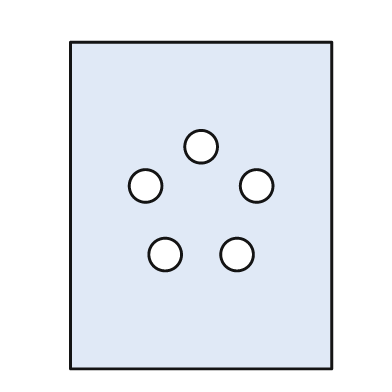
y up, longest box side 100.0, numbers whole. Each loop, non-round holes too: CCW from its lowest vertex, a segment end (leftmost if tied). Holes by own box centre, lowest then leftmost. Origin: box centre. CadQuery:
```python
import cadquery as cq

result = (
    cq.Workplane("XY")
    .moveTo(-40.0, -50.0)
    .lineTo(40.0, -50.0)
    .lineTo(40.0, 50.0)
    .lineTo(-40.0, 50.0)
    .close()
    .moveTo(-11.0, -15.0)
    .circle(5.0)
    .moveTo(11.0, -15.0)
    .circle(5.0)
    .moveTo(-17.0, 6.0)
    .circle(5.0)
    .moveTo(17.0, 6.0)
    .circle(5.0)
    .moveTo(0.0, 18.0)
    .circle(5.0)
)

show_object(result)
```